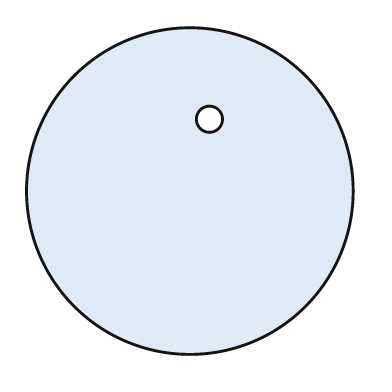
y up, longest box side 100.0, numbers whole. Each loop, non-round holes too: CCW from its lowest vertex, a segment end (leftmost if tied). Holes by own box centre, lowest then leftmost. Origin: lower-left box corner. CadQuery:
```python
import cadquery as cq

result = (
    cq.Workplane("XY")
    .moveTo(50.0, 50.0)
    .circle(50.0)
    .moveTo(56.0, 72.0)
    .circle(4.0)
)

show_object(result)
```